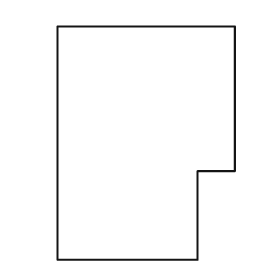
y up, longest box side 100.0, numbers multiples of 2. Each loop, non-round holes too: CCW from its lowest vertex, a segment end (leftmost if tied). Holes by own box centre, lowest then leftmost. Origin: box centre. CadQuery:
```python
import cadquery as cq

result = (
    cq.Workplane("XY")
    .moveTo(-38.0, -50.0)
    .lineTo(22.0, -50.0)
    .lineTo(22.0, -12.0)
    .lineTo(38.0, -12.0)
    .lineTo(38.0, 50.0)
    .lineTo(-38.0, 50.0)
    .close()
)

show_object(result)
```